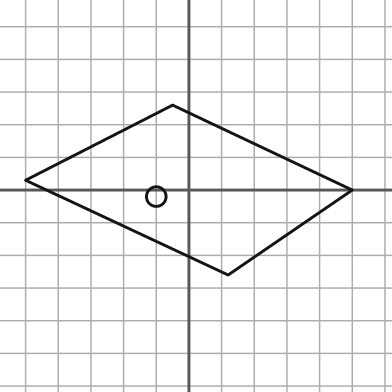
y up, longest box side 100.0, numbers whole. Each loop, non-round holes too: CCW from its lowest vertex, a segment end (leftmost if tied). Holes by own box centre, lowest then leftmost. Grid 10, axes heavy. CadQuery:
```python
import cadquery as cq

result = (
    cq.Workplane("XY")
    .moveTo(12.0, -26.0)
    .lineTo(50.0, 0.0)
    .lineTo(-5.0, 26.0)
    .lineTo(-50.0, 3.0)
    .close()
    .moveTo(-10.0, -2.0)
    .circle(3.0)
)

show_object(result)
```